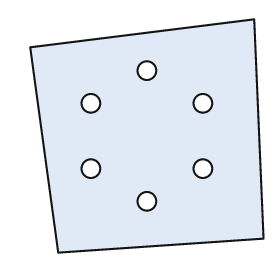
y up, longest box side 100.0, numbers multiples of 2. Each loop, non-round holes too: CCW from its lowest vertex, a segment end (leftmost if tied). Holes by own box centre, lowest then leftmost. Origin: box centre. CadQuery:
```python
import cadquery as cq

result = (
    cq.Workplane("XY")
    .moveTo(-38.0, -50.0)
    .lineTo(50.0, -44.0)
    .lineTo(46.0, 50.0)
    .lineTo(-50.0, 38.0)
    .close()
    .moveTo(0.0, -28.0)
    .circle(4.0)
    .moveTo(-24.0, -14.0)
    .circle(4.0)
    .moveTo(24.0, -14.0)
    .circle(4.0)
    .moveTo(-24.0, 14.0)
    .circle(4.0)
    .moveTo(24.0, 14.0)
    .circle(4.0)
    .moveTo(0.0, 28.0)
    .circle(4.0)
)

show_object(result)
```